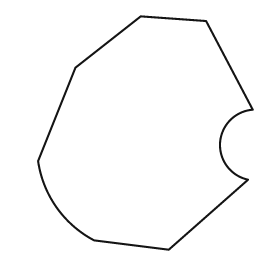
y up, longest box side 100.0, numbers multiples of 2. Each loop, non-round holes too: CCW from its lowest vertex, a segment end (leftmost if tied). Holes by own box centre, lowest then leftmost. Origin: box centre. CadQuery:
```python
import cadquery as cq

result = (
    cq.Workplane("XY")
    .moveTo(10.0, -50.0)
    .lineTo(44.0, -20.0)
    .threePointArc((32.0, -4.0), (46.0, 10.0))
    .lineTo(26.0, 48.0)
    .lineTo(-2.0, 50.0)
    .lineTo(-30.0, 28.0)
    .lineTo(-46.0, -12.0)
    .threePointArc((-38.0, -32.0), (-22.0, -46.0))
    .close()
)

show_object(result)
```